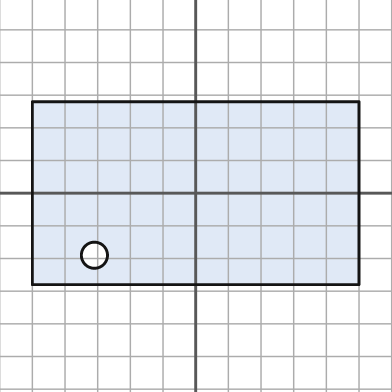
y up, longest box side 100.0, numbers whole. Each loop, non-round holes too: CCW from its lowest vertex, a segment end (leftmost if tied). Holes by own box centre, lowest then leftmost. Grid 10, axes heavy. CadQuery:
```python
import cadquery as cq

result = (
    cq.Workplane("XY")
    .moveTo(-50.0, -28.0)
    .lineTo(50.0, -28.0)
    .lineTo(50.0, 28.0)
    .lineTo(-50.0, 28.0)
    .close()
    .moveTo(-31.0, -19.0)
    .circle(4.0)
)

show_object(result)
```